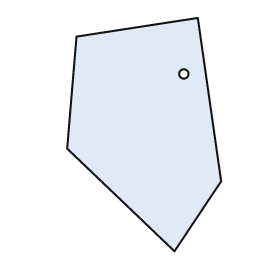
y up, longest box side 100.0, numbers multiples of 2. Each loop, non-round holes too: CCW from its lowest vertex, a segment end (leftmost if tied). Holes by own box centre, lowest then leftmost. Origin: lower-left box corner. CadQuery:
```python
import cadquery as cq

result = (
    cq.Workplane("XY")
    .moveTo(46.0, 0.0)
    .lineTo(66.0, 30.0)
    .lineTo(56.0, 100.0)
    .lineTo(4.0, 92.0)
    .lineTo(0.0, 44.0)
    .close()
    .moveTo(50.0, 76.0)
    .circle(2.0)
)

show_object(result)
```